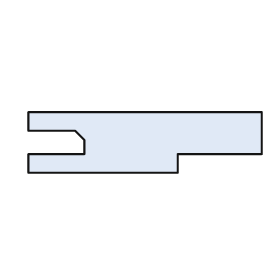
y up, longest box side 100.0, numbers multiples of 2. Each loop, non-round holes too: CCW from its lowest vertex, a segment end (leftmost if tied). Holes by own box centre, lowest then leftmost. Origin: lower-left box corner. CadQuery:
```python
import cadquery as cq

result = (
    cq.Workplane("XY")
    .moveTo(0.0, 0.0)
    .lineTo(64.0, 0.0)
    .lineTo(64.0, 8.0)
    .lineTo(100.0, 8.0)
    .lineTo(100.0, 26.0)
    .lineTo(0.0, 26.0)
    .lineTo(0.0, 18.0)
    .lineTo(20.0, 18.0)
    .lineTo(24.0, 14.0)
    .lineTo(24.0, 8.0)
    .lineTo(0.0, 8.0)
    .close()
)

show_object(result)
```